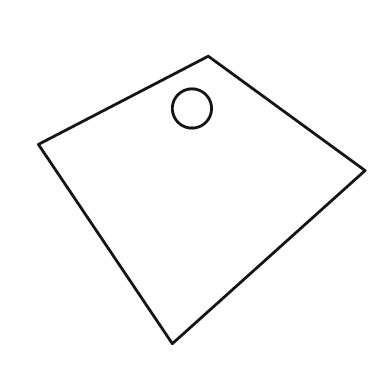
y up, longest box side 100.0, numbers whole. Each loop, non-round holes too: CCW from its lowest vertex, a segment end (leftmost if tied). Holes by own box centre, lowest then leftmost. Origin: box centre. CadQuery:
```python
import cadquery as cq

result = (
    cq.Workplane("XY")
    .moveTo(-9.0, -44.0)
    .lineTo(50.0, 9.0)
    .lineTo(2.0, 44.0)
    .lineTo(-50.0, 17.0)
    .close()
    .moveTo(-3.0, 28.0)
    .circle(6.0)
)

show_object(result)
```